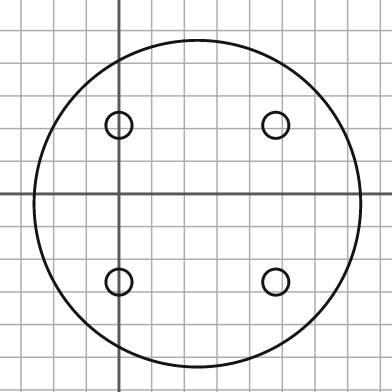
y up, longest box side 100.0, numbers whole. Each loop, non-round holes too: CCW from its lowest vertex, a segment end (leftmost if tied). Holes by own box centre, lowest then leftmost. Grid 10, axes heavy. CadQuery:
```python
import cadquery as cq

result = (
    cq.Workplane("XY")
    .moveTo(24.0, -3.0)
    .circle(50.0)
    .moveTo(0.0, -27.0)
    .circle(4.0)
    .moveTo(48.0, -27.0)
    .circle(4.0)
    .moveTo(0.0, 21.0)
    .circle(4.0)
    .moveTo(48.0, 21.0)
    .circle(4.0)
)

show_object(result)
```